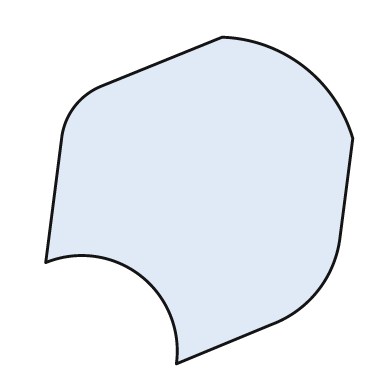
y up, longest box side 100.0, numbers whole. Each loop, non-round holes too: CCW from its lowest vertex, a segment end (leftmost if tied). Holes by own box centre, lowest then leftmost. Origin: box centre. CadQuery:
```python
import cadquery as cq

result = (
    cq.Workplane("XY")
    .moveTo(-7.0, -50.0)
    .lineTo(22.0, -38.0)
    .threePointArc((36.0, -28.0), (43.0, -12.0))
    .lineTo(47.0, 19.0)
    .threePointArc((32.0, 41.0), (7.0, 50.0))
    .lineTo(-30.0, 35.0)
    .threePointArc((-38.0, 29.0), (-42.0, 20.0))
    .lineTo(-47.0, -19.0)
    .threePointArc((-18.0, -23.0), (-7.0, -50.0))
    .close()
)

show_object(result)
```